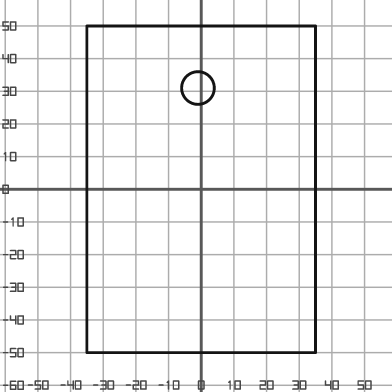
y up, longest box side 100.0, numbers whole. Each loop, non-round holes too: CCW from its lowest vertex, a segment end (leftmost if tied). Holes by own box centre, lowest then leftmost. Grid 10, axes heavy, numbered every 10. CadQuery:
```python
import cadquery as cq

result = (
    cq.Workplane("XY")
    .moveTo(-35.0, -50.0)
    .lineTo(35.0, -50.0)
    .lineTo(35.0, 50.0)
    .lineTo(-35.0, 50.0)
    .close()
    .moveTo(-1.0, 31.0)
    .circle(5.0)
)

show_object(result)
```